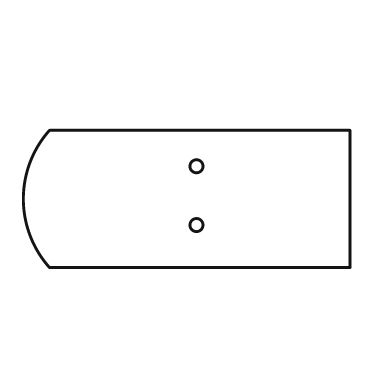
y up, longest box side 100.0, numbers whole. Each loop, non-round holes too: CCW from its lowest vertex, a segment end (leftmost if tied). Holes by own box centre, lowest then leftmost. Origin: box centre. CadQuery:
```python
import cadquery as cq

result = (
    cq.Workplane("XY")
    .moveTo(-42.0, -21.0)
    .lineTo(50.0, -21.0)
    .lineTo(50.0, 21.0)
    .lineTo(-42.0, 21.0)
    .threePointArc((-50.0, 0.0), (-42.0, -21.0))
    .close()
    .moveTo(3.0, -8.0)
    .circle(2.0)
    .moveTo(3.0, 10.0)
    .circle(2.0)
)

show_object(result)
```